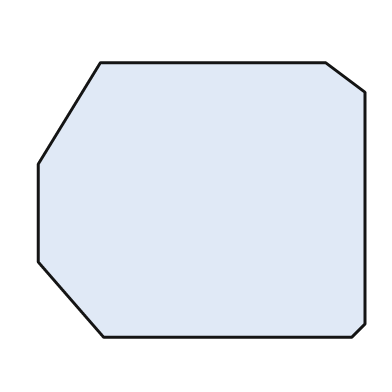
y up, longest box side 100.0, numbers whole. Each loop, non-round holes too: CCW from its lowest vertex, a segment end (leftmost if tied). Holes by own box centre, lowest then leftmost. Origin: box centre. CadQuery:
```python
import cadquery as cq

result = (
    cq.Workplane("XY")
    .moveTo(-30.0, -42.0)
    .lineTo(46.0, -42.0)
    .lineTo(50.0, -38.0)
    .lineTo(50.0, 33.0)
    .lineTo(38.0, 42.0)
    .lineTo(-31.0, 42.0)
    .lineTo(-50.0, 11.0)
    .lineTo(-50.0, -19.0)
    .close()
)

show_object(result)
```